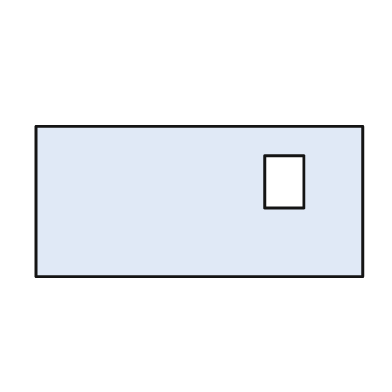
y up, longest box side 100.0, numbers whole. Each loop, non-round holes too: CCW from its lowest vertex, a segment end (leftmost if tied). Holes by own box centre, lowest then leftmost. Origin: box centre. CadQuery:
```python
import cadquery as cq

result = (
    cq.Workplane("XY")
    .moveTo(-50.0, -23.0)
    .lineTo(50.0, -23.0)
    .lineTo(50.0, 23.0)
    .lineTo(-50.0, 23.0)
    .close()
    .moveTo(20.0, -2.0)
    .lineTo(32.0, -2.0)
    .lineTo(32.0, 14.0)
    .lineTo(20.0, 14.0)
    .close()
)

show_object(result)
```